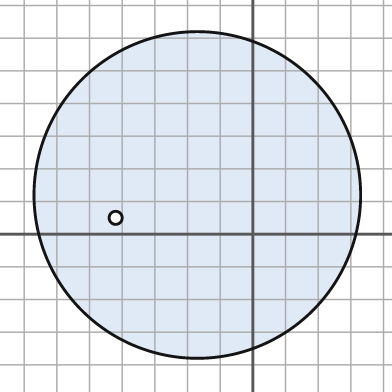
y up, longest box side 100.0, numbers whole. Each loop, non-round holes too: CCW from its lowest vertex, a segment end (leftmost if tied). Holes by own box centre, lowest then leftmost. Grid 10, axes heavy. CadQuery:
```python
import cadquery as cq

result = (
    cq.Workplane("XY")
    .moveTo(-17.0, 12.0)
    .circle(50.0)
    .moveTo(-42.0, 5.0)
    .circle(2.0)
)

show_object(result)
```